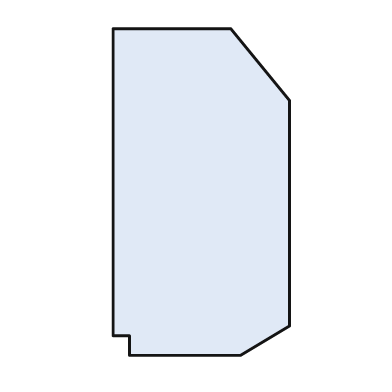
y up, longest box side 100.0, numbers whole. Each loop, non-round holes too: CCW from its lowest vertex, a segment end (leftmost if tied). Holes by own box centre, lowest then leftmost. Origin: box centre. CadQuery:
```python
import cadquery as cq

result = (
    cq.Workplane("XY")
    .moveTo(-22.0, -50.0)
    .lineTo(12.0, -50.0)
    .lineTo(27.0, -41.0)
    .lineTo(27.0, 28.0)
    .lineTo(9.0, 50.0)
    .lineTo(-27.0, 50.0)
    .lineTo(-27.0, -44.0)
    .lineTo(-22.0, -44.0)
    .close()
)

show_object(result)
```